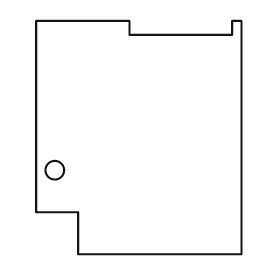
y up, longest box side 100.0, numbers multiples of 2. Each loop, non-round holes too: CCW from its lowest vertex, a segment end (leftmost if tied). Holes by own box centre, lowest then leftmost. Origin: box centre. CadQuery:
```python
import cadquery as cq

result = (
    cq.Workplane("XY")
    .moveTo(-26.0, -50.0)
    .lineTo(44.0, -50.0)
    .lineTo(44.0, 50.0)
    .lineTo(40.0, 50.0)
    .lineTo(40.0, 44.0)
    .lineTo(-4.0, 44.0)
    .lineTo(-4.0, 50.0)
    .lineTo(-44.0, 50.0)
    .lineTo(-44.0, -32.0)
    .lineTo(-26.0, -32.0)
    .close()
    .moveTo(-36.0, -14.0)
    .circle(4.0)
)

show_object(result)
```